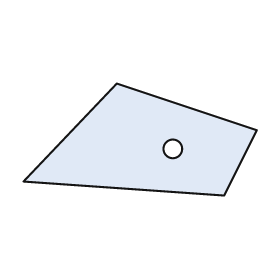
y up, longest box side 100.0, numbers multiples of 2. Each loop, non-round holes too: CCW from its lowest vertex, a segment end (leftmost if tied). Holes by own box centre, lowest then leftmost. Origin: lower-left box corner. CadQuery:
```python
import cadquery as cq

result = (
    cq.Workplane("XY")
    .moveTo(86.0, 0.0)
    .lineTo(100.0, 28.0)
    .lineTo(40.0, 48.0)
    .lineTo(0.0, 6.0)
    .close()
    .moveTo(64.0, 20.0)
    .circle(4.0)
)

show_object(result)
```